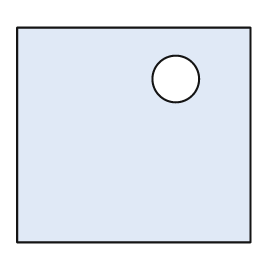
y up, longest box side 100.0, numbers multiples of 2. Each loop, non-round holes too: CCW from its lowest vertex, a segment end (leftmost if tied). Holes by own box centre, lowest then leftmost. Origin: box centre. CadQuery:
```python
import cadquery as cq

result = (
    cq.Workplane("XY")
    .moveTo(-50.0, -46.0)
    .lineTo(50.0, -46.0)
    .lineTo(50.0, 46.0)
    .lineTo(-50.0, 46.0)
    .close()
    .moveTo(18.0, 24.0)
    .circle(10.0)
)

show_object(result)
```